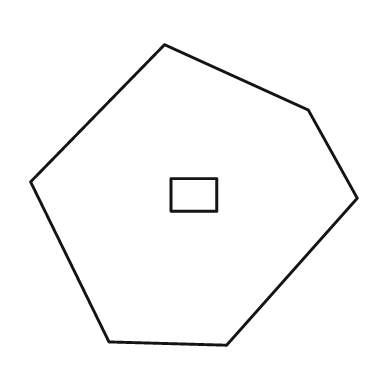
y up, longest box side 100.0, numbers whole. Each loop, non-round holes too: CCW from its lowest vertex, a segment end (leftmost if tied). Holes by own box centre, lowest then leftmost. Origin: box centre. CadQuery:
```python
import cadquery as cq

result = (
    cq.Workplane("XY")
    .moveTo(10.0, -46.0)
    .lineTo(50.0, -1.0)
    .lineTo(35.0, 26.0)
    .lineTo(-9.0, 46.0)
    .lineTo(-50.0, 4.0)
    .lineTo(-26.0, -45.0)
    .close()
    .moveTo(-7.0, -5.0)
    .lineTo(7.0, -5.0)
    .lineTo(7.0, 5.0)
    .lineTo(-7.0, 5.0)
    .close()
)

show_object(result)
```